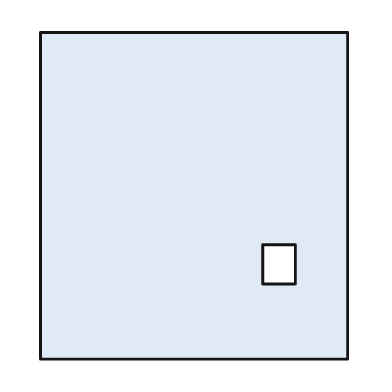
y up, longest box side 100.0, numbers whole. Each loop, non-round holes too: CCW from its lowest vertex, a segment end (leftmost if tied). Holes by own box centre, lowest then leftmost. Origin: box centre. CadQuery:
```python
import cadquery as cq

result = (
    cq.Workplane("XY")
    .moveTo(-47.0, -50.0)
    .lineTo(47.0, -50.0)
    .lineTo(47.0, 50.0)
    .lineTo(-47.0, 50.0)
    .close()
    .moveTo(21.0, -27.0)
    .lineTo(31.0, -27.0)
    .lineTo(31.0, -15.0)
    .lineTo(21.0, -15.0)
    .close()
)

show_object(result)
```